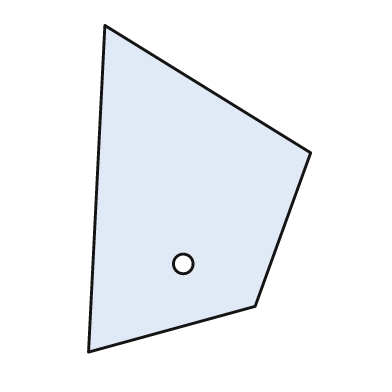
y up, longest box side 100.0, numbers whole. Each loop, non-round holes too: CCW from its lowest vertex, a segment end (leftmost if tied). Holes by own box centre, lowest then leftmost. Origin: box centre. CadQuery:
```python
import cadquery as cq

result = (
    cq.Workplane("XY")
    .moveTo(-34.0, -50.0)
    .lineTo(17.0, -36.0)
    .lineTo(34.0, 11.0)
    .lineTo(-29.0, 50.0)
    .close()
    .moveTo(-5.0, -23.0)
    .circle(3.0)
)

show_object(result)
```